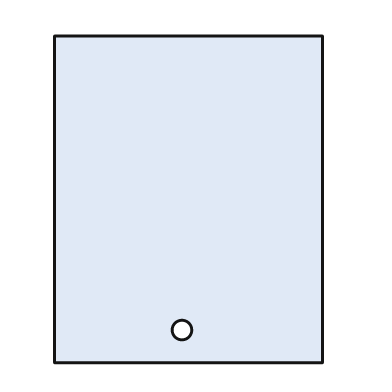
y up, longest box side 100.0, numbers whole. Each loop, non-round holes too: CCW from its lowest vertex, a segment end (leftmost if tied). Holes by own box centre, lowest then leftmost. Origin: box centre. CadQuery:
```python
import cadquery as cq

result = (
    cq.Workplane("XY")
    .moveTo(-41.0, -50.0)
    .lineTo(41.0, -50.0)
    .lineTo(41.0, 50.0)
    .lineTo(-41.0, 50.0)
    .close()
    .moveTo(-2.0, -40.0)
    .circle(3.0)
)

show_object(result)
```